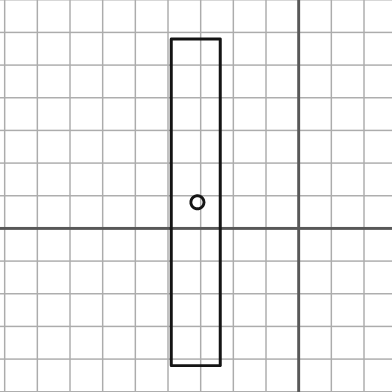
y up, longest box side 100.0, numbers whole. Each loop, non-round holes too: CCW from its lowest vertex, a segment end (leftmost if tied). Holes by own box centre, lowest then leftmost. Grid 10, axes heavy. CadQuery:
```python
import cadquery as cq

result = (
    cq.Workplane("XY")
    .moveTo(-39.0, -42.0)
    .lineTo(-24.0, -42.0)
    .lineTo(-24.0, 58.0)
    .lineTo(-39.0, 58.0)
    .close()
    .moveTo(-31.0, 8.0)
    .circle(2.0)
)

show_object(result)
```